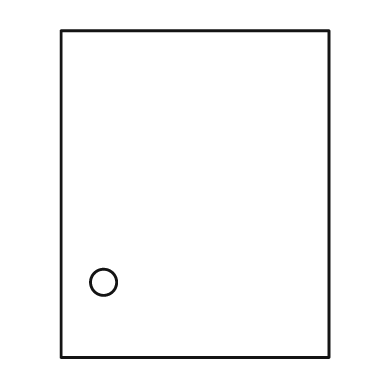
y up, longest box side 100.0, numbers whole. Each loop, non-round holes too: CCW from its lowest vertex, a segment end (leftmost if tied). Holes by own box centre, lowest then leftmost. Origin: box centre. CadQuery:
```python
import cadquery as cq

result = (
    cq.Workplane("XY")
    .moveTo(-41.0, -50.0)
    .lineTo(41.0, -50.0)
    .lineTo(41.0, 50.0)
    .lineTo(-41.0, 50.0)
    .close()
    .moveTo(-28.0, -27.0)
    .circle(4.0)
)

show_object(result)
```